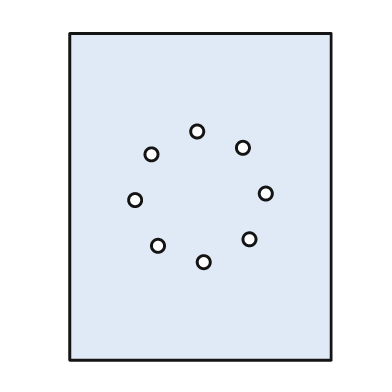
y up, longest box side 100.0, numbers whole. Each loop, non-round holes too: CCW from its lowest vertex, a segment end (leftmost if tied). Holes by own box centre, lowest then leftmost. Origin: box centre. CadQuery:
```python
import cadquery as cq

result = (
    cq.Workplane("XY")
    .moveTo(-40.0, -50.0)
    .lineTo(40.0, -50.0)
    .lineTo(40.0, 50.0)
    .lineTo(-40.0, 50.0)
    .close()
    .moveTo(1.0, -20.0)
    .circle(2.0)
    .moveTo(-13.0, -15.0)
    .circle(2.0)
    .moveTo(15.0, -13.0)
    .circle(2.0)
    .moveTo(-20.0, -1.0)
    .circle(2.0)
    .moveTo(20.0, 1.0)
    .circle(2.0)
    .moveTo(-15.0, 13.0)
    .circle(2.0)
    .moveTo(13.0, 15.0)
    .circle(2.0)
    .moveTo(-1.0, 20.0)
    .circle(2.0)
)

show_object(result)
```